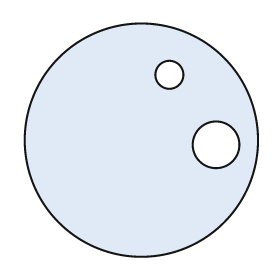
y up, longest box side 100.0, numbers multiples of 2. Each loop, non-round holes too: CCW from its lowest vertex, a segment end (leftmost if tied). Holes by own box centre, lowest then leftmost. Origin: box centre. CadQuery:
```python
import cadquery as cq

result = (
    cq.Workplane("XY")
    .moveTo(0.0, 0.0)
    .circle(50.0)
    .moveTo(32.0, -2.0)
    .circle(10.0)
    .moveTo(12.0, 28.0)
    .circle(6.0)
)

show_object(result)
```